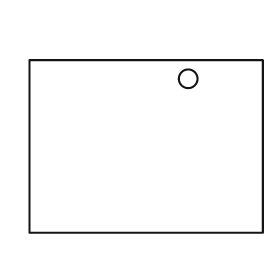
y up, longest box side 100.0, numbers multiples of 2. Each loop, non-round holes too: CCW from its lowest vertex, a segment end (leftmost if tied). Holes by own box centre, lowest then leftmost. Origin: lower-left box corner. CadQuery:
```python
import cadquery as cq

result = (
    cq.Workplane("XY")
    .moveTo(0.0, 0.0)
    .lineTo(100.0, 0.0)
    .lineTo(100.0, 74.0)
    .lineTo(0.0, 74.0)
    .close()
    .moveTo(68.0, 66.0)
    .circle(4.0)
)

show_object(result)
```